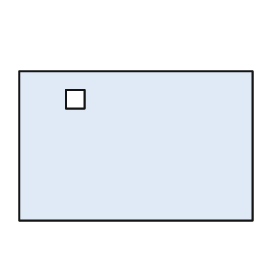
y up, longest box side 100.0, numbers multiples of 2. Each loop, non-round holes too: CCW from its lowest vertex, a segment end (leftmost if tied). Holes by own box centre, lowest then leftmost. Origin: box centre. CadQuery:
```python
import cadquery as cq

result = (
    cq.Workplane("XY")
    .moveTo(-50.0, -32.0)
    .lineTo(50.0, -32.0)
    .lineTo(50.0, 32.0)
    .lineTo(-50.0, 32.0)
    .close()
    .moveTo(-30.0, 16.0)
    .lineTo(-22.0, 16.0)
    .lineTo(-22.0, 24.0)
    .lineTo(-30.0, 24.0)
    .close()
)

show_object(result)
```